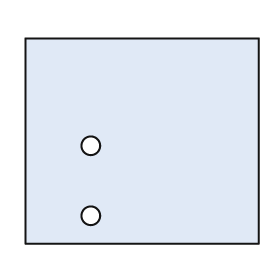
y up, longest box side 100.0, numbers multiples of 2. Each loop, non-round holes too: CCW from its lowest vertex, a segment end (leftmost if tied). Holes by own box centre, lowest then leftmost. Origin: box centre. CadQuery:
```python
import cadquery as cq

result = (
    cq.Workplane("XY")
    .moveTo(-50.0, -44.0)
    .lineTo(50.0, -44.0)
    .lineTo(50.0, 44.0)
    .lineTo(-50.0, 44.0)
    .close()
    .moveTo(-22.0, -32.0)
    .circle(4.0)
    .moveTo(-22.0, -2.0)
    .circle(4.0)
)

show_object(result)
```